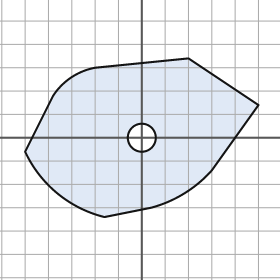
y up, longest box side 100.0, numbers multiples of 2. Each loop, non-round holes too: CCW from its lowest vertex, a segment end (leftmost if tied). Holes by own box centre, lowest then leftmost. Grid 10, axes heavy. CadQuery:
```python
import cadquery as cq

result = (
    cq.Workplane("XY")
    .moveTo(-16.0, -34.0)
    .lineTo(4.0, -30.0)
    .threePointArc((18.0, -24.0), (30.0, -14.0))
    .lineTo(50.0, 14.0)
    .lineTo(20.0, 34.0)
    .lineTo(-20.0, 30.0)
    .threePointArc((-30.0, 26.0), (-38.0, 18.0))
    .lineTo(-50.0, -6.0)
    .threePointArc((-36.0, -24.0), (-16.0, -34.0))
    .close()
    .moveTo(0.0, 0.0)
    .circle(6.0)
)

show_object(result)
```